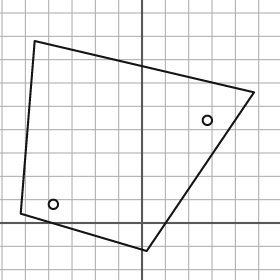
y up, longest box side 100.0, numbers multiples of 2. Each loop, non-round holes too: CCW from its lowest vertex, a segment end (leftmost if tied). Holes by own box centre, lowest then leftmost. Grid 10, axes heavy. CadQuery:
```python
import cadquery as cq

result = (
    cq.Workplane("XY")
    .moveTo(2.0, -12.0)
    .lineTo(48.0, 56.0)
    .lineTo(-46.0, 78.0)
    .lineTo(-52.0, 4.0)
    .close()
    .moveTo(-38.0, 8.0)
    .circle(2.0)
    .moveTo(28.0, 44.0)
    .circle(2.0)
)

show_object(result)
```